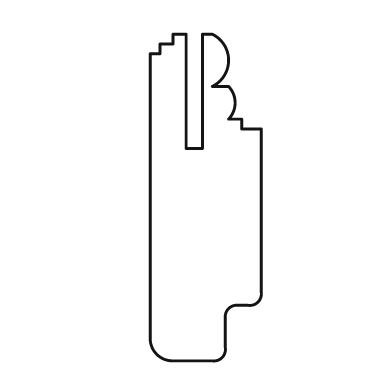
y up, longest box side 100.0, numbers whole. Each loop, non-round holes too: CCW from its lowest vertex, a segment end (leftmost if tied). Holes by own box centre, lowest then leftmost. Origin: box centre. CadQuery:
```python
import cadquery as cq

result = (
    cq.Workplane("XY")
    .moveTo(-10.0, -50.0)
    .lineTo(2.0, -50.0)
    .threePointArc((5.0, -49.0), (6.0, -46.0))
    .lineTo(6.0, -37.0)
    .threePointArc((7.0, -34.0), (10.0, -33.0))
    .lineTo(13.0, -33.0)
    .threePointArc((16.0, -32.0), (17.0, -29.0))
    .lineTo(17.0, 21.0)
    .lineTo(11.0, 21.0)
    .lineTo(11.0, 24.0)
    .lineTo(7.0, 24.0)
    .threePointArc((9.0, 29.0), (7.0, 34.0))
    .lineTo(2.0, 34.0)
    .threePointArc((7.0, 42.0), (2.0, 50.0))
    .lineTo(-1.0, 50.0)
    .lineTo(-1.0, 15.0)
    .lineTo(-6.0, 15.0)
    .lineTo(-6.0, 50.0)
    .lineTo(-10.0, 50.0)
    .lineTo(-10.0, 47.0)
    .lineTo(-14.0, 47.0)
    .lineTo(-14.0, 44.0)
    .lineTo(-17.0, 44.0)
    .lineTo(-17.0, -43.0)
    .threePointArc((-15.0, -48.0), (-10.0, -50.0))
    .close()
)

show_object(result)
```